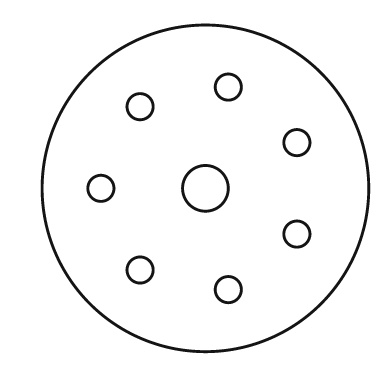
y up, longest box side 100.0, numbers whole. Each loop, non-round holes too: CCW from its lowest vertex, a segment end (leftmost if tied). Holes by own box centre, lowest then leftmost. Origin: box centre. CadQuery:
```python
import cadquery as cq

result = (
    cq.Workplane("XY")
    .moveTo(0.0, 0.0)
    .circle(50.0)
    .moveTo(7.0, -31.0)
    .circle(4.0)
    .moveTo(-20.0, -25.0)
    .circle(4.0)
    .moveTo(28.0, -14.0)
    .circle(4.0)
    .moveTo(-32.0, 0.0)
    .circle(4.0)
    .moveTo(0.0, 0.0)
    .circle(7.0)
    .moveTo(28.0, 14.0)
    .circle(4.0)
    .moveTo(-20.0, 25.0)
    .circle(4.0)
    .moveTo(7.0, 31.0)
    .circle(4.0)
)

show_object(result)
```